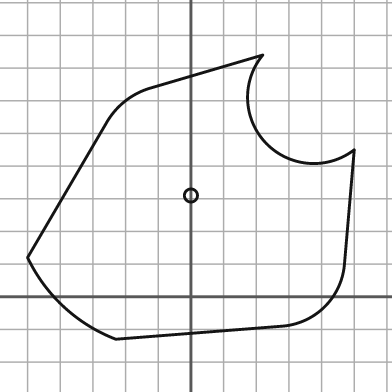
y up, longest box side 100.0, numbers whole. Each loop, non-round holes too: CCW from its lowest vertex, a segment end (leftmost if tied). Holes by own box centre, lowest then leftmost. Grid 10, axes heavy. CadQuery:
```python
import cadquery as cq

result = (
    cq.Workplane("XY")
    .moveTo(-23.0, -13.0)
    .lineTo(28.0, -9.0)
    .threePointArc((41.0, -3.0), (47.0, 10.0))
    .lineTo(50.0, 45.0)
    .threePointArc((23.0, 47.0), (22.0, 74.0))
    .lineTo(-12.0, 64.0)
    .threePointArc((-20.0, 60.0), (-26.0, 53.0))
    .lineTo(-50.0, 12.0)
    .threePointArc((-39.0, -3.0), (-23.0, -13.0))
    .close()
    .moveTo(0.0, 31.0)
    .circle(2.0)
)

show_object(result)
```